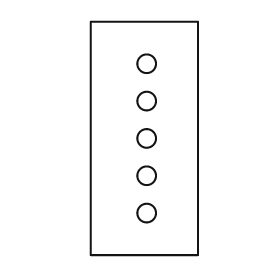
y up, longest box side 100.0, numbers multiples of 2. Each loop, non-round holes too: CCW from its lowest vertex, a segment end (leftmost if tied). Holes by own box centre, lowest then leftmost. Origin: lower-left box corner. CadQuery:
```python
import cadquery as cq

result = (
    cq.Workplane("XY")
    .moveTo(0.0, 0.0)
    .lineTo(46.0, 0.0)
    .lineTo(46.0, 100.0)
    .lineTo(0.0, 100.0)
    .close()
    .moveTo(24.0, 18.0)
    .circle(4.0)
    .moveTo(24.0, 34.0)
    .circle(4.0)
    .moveTo(24.0, 50.0)
    .circle(4.0)
    .moveTo(24.0, 66.0)
    .circle(4.0)
    .moveTo(24.0, 82.0)
    .circle(4.0)
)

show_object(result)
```